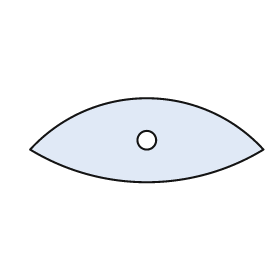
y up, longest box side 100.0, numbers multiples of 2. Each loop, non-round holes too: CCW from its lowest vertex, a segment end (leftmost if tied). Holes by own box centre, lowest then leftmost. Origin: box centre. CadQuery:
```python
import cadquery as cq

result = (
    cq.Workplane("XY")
    .moveTo(-50.0, -4.0)
    .threePointArc((0.0, -18.0), (50.0, -4.0))
    .threePointArc((0.0, 18.0), (-50.0, -4.0))
    .close()
    .moveTo(0.0, 0.0)
    .circle(4.0)
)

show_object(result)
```